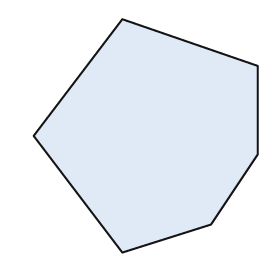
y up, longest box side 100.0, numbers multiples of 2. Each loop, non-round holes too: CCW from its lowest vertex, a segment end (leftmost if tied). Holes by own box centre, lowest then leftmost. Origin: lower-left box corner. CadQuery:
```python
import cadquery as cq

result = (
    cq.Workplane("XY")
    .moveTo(38.0, 0.0)
    .lineTo(76.0, 12.0)
    .lineTo(96.0, 42.0)
    .lineTo(96.0, 80.0)
    .lineTo(38.0, 100.0)
    .lineTo(0.0, 50.0)
    .close()
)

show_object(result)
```